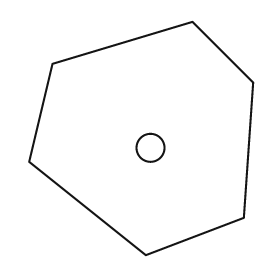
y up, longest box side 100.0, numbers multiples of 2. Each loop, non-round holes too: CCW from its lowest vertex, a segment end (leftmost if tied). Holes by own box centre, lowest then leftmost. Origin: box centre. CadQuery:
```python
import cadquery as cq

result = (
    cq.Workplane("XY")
    .moveTo(2.0, -50.0)
    .lineTo(44.0, -34.0)
    .lineTo(48.0, 24.0)
    .lineTo(22.0, 50.0)
    .lineTo(-38.0, 32.0)
    .lineTo(-48.0, -10.0)
    .close()
    .moveTo(4.0, -4.0)
    .circle(6.0)
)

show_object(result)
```